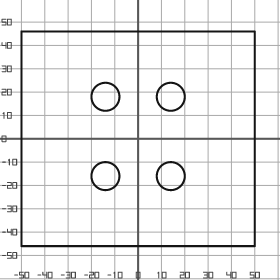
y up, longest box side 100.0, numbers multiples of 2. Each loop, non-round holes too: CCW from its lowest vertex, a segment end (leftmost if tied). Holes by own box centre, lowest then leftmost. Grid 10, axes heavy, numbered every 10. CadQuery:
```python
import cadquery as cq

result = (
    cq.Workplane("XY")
    .moveTo(-50.0, -46.0)
    .lineTo(50.0, -46.0)
    .lineTo(50.0, 46.0)
    .lineTo(-50.0, 46.0)
    .close()
    .moveTo(-14.0, -16.0)
    .circle(6.0)
    .moveTo(14.0, -16.0)
    .circle(6.0)
    .moveTo(-14.0, 18.0)
    .circle(6.0)
    .moveTo(14.0, 18.0)
    .circle(6.0)
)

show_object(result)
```